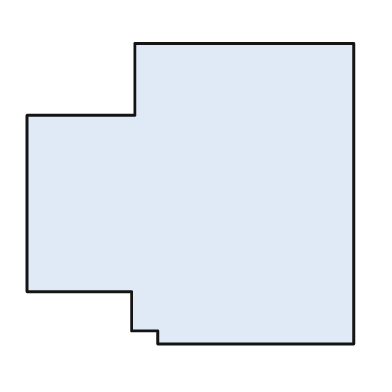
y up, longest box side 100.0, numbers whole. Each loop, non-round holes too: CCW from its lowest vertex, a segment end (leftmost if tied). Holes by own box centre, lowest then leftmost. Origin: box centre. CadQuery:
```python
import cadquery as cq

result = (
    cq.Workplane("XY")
    .moveTo(-10.0, -46.0)
    .lineTo(50.0, -46.0)
    .lineTo(50.0, 46.0)
    .lineTo(-17.0, 46.0)
    .lineTo(-17.0, 24.0)
    .lineTo(-50.0, 24.0)
    .lineTo(-50.0, -30.0)
    .lineTo(-18.0, -30.0)
    .lineTo(-18.0, -42.0)
    .lineTo(-10.0, -42.0)
    .close()
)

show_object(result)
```